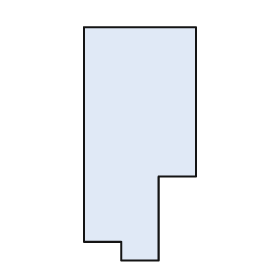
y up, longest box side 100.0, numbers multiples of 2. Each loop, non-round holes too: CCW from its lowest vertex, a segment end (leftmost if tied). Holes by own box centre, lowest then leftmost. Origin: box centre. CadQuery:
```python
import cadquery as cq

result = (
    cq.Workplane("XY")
    .moveTo(-8.0, -50.0)
    .lineTo(8.0, -50.0)
    .lineTo(8.0, -14.0)
    .lineTo(24.0, -14.0)
    .lineTo(24.0, 50.0)
    .lineTo(-24.0, 50.0)
    .lineTo(-24.0, -42.0)
    .lineTo(-8.0, -42.0)
    .close()
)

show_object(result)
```